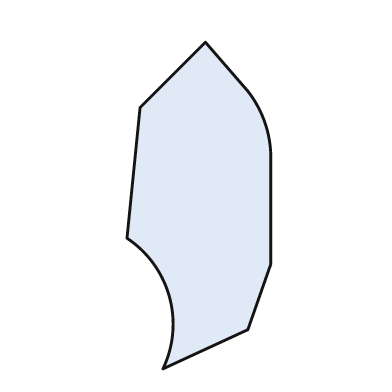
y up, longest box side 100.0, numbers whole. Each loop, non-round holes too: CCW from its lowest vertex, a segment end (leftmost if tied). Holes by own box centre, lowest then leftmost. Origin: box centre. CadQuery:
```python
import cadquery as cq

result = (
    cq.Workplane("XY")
    .moveTo(-11.0, -50.0)
    .lineTo(15.0, -38.0)
    .lineTo(22.0, -18.0)
    .lineTo(22.0, 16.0)
    .threePointArc((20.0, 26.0), (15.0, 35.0))
    .lineTo(2.0, 50.0)
    .lineTo(-18.0, 30.0)
    .lineTo(-22.0, -10.0)
    .threePointArc((-9.0, -28.0), (-11.0, -50.0))
    .close()
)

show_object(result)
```